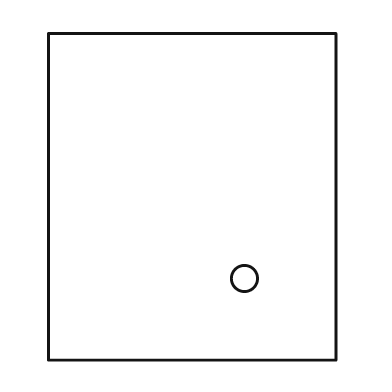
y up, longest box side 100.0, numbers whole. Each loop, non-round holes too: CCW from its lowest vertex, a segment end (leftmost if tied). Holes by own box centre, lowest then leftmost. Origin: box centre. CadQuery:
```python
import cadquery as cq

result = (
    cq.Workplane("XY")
    .moveTo(-44.0, -50.0)
    .lineTo(44.0, -50.0)
    .lineTo(44.0, 50.0)
    .lineTo(-44.0, 50.0)
    .close()
    .moveTo(16.0, -25.0)
    .circle(4.0)
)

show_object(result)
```